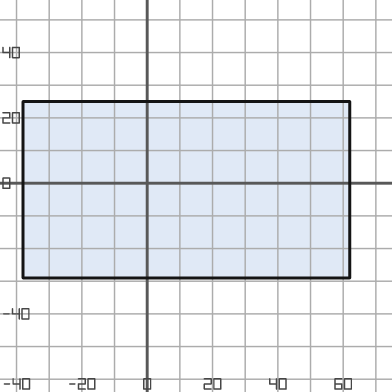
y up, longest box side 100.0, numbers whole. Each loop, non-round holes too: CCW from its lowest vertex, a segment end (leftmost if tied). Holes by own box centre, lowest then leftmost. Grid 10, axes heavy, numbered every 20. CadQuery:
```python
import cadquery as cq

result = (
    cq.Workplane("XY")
    .moveTo(-38.0, -29.0)
    .lineTo(62.0, -29.0)
    .lineTo(62.0, 25.0)
    .lineTo(-38.0, 25.0)
    .close()
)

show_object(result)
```